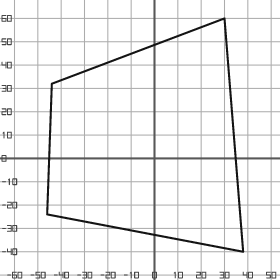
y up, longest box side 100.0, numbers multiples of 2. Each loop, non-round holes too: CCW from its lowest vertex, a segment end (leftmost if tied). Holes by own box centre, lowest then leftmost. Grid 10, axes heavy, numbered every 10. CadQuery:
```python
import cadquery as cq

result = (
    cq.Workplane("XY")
    .moveTo(38.0, -40.0)
    .lineTo(30.0, 60.0)
    .lineTo(-44.0, 32.0)
    .lineTo(-46.0, -24.0)
    .close()
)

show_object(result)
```